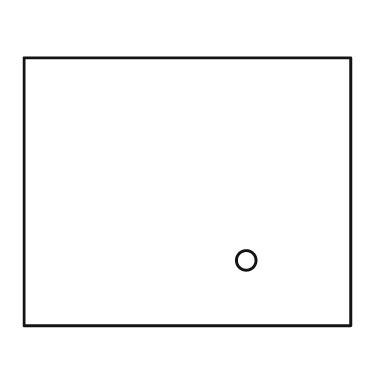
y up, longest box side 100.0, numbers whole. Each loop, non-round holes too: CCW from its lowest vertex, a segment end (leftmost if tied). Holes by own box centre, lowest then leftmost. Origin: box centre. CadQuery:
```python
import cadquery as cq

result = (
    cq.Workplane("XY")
    .moveTo(-50.0, -41.0)
    .lineTo(50.0, -41.0)
    .lineTo(50.0, 41.0)
    .lineTo(-50.0, 41.0)
    .close()
    .moveTo(18.0, -21.0)
    .circle(3.0)
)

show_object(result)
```